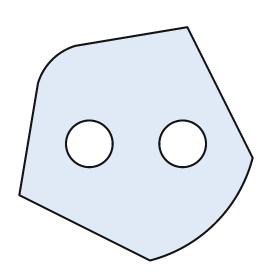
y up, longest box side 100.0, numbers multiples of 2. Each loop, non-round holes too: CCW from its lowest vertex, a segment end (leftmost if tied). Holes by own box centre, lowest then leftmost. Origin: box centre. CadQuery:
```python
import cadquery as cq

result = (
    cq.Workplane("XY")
    .moveTo(6.0, -50.0)
    .threePointArc((34.0, -34.0), (50.0, -6.0))
    .lineTo(22.0, 50.0)
    .lineTo(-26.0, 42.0)
    .threePointArc((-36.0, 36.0), (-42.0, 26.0))
    .lineTo(-50.0, -22.0)
    .close()
    .moveTo(-20.0, 0.0)
    .circle(10.0)
    .moveTo(20.0, 0.0)
    .circle(10.0)
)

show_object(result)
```